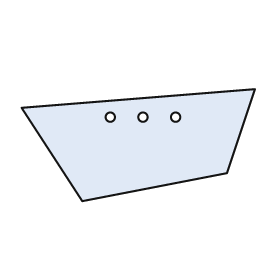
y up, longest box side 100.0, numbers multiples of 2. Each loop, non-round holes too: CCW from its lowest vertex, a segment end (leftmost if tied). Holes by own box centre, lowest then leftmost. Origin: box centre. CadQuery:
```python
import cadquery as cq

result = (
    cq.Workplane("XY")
    .moveTo(-24.0, -24.0)
    .lineTo(38.0, -12.0)
    .lineTo(50.0, 24.0)
    .lineTo(-50.0, 16.0)
    .close()
    .moveTo(-12.0, 12.0)
    .circle(2.0)
    .moveTo(2.0, 12.0)
    .circle(2.0)
    .moveTo(16.0, 12.0)
    .circle(2.0)
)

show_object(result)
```